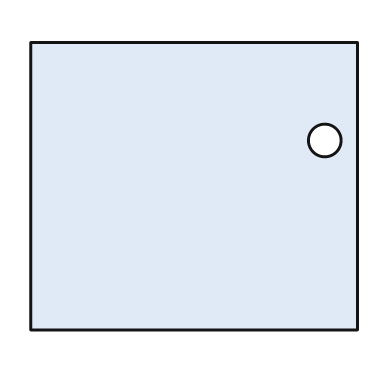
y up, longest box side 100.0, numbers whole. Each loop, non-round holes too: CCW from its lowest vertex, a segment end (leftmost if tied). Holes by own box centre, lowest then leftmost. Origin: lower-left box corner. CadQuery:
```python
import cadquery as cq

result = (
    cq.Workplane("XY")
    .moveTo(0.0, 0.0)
    .lineTo(100.0, 0.0)
    .lineTo(100.0, 88.0)
    .lineTo(0.0, 88.0)
    .close()
    .moveTo(90.0, 58.0)
    .circle(5.0)
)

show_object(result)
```